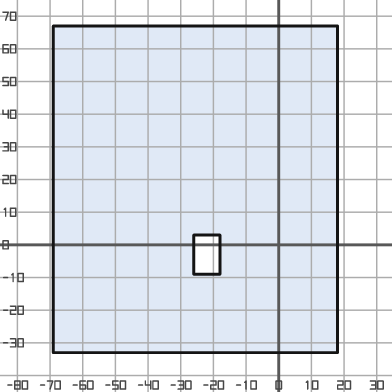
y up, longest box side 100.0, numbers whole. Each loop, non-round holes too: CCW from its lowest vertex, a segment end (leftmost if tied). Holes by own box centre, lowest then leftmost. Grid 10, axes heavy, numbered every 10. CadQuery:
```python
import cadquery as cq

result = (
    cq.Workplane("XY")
    .moveTo(-69.0, -33.0)
    .lineTo(18.0, -33.0)
    .lineTo(18.0, 67.0)
    .lineTo(-69.0, 67.0)
    .close()
    .moveTo(-26.0, -9.0)
    .lineTo(-18.0, -9.0)
    .lineTo(-18.0, 3.0)
    .lineTo(-26.0, 3.0)
    .close()
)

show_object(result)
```